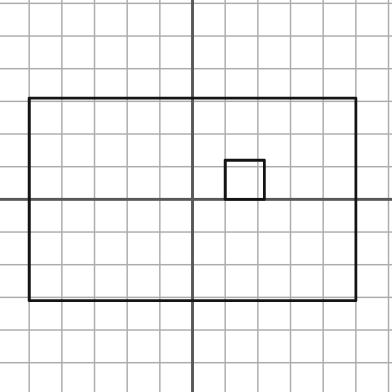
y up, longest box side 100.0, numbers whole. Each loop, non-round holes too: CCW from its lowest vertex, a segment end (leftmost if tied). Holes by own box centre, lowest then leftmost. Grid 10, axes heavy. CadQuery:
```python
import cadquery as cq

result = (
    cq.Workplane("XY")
    .moveTo(-50.0, -31.0)
    .lineTo(50.0, -31.0)
    .lineTo(50.0, 31.0)
    .lineTo(-50.0, 31.0)
    .close()
    .moveTo(10.0, 0.0)
    .lineTo(22.0, 0.0)
    .lineTo(22.0, 12.0)
    .lineTo(10.0, 12.0)
    .close()
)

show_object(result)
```